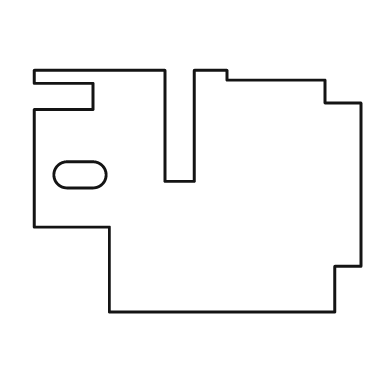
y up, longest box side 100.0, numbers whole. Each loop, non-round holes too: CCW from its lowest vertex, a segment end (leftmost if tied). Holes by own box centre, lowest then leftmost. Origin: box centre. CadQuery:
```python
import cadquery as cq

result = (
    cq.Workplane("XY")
    .moveTo(-27.0, -37.0)
    .lineTo(42.0, -37.0)
    .lineTo(42.0, -23.0)
    .lineTo(50.0, -23.0)
    .lineTo(50.0, 27.0)
    .lineTo(39.0, 27.0)
    .lineTo(39.0, 34.0)
    .lineTo(9.0, 34.0)
    .lineTo(9.0, 37.0)
    .lineTo(-1.0, 37.0)
    .lineTo(-1.0, 3.0)
    .lineTo(-10.0, 3.0)
    .lineTo(-10.0, 37.0)
    .lineTo(-50.0, 37.0)
    .lineTo(-50.0, 33.0)
    .lineTo(-32.0, 33.0)
    .lineTo(-32.0, 25.0)
    .lineTo(-50.0, 25.0)
    .lineTo(-50.0, -11.0)
    .lineTo(-27.0, -11.0)
    .close()
    .moveTo(-40.0, 1.0)
    .lineTo(-32.0, 1.0)
    .threePointArc((-28.0, 5.0), (-32.0, 9.0))
    .lineTo(-40.0, 9.0)
    .threePointArc((-44.0, 5.0), (-40.0, 1.0))
    .close()
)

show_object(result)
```